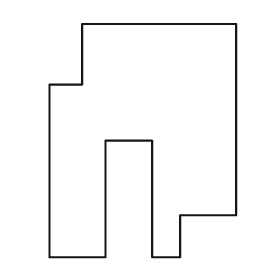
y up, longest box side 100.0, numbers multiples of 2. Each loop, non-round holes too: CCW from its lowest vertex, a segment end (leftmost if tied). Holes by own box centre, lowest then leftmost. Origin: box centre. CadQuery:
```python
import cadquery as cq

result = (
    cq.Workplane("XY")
    .moveTo(-40.0, -50.0)
    .lineTo(-16.0, -50.0)
    .lineTo(-16.0, 0.0)
    .lineTo(4.0, 0.0)
    .lineTo(4.0, -50.0)
    .lineTo(16.0, -50.0)
    .lineTo(16.0, -32.0)
    .lineTo(40.0, -32.0)
    .lineTo(40.0, 50.0)
    .lineTo(-26.0, 50.0)
    .lineTo(-26.0, 24.0)
    .lineTo(-40.0, 24.0)
    .close()
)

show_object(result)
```